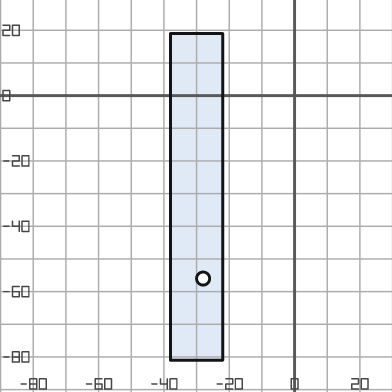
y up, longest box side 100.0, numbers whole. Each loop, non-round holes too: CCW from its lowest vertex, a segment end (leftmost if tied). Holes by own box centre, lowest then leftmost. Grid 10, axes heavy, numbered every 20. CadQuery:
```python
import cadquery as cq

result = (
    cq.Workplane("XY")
    .moveTo(-38.0, -81.0)
    .lineTo(-22.0, -81.0)
    .lineTo(-22.0, 19.0)
    .lineTo(-38.0, 19.0)
    .close()
    .moveTo(-28.0, -56.0)
    .circle(2.0)
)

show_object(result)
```